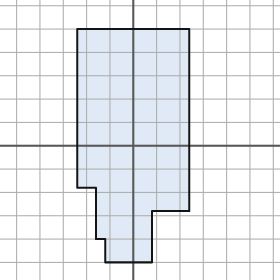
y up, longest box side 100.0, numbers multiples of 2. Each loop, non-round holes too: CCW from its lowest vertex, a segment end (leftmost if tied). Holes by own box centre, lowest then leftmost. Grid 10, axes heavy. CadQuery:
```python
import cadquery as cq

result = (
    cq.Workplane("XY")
    .moveTo(-12.0, -50.0)
    .lineTo(8.0, -50.0)
    .lineTo(8.0, -28.0)
    .lineTo(24.0, -28.0)
    .lineTo(24.0, 50.0)
    .lineTo(-24.0, 50.0)
    .lineTo(-24.0, -18.0)
    .lineTo(-16.0, -18.0)
    .lineTo(-16.0, -40.0)
    .lineTo(-12.0, -40.0)
    .close()
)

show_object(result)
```